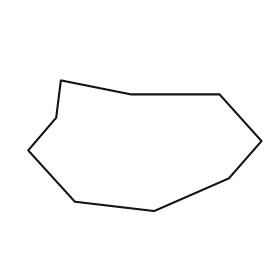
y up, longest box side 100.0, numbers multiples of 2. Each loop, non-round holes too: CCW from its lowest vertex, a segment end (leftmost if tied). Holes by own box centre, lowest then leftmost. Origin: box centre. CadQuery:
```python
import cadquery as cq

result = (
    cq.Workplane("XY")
    .moveTo(4.0, -28.0)
    .lineTo(36.0, -14.0)
    .lineTo(50.0, 2.0)
    .lineTo(32.0, 22.0)
    .lineTo(-6.0, 22.0)
    .lineTo(-36.0, 28.0)
    .lineTo(-38.0, 12.0)
    .lineTo(-50.0, -2.0)
    .lineTo(-30.0, -24.0)
    .close()
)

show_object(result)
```